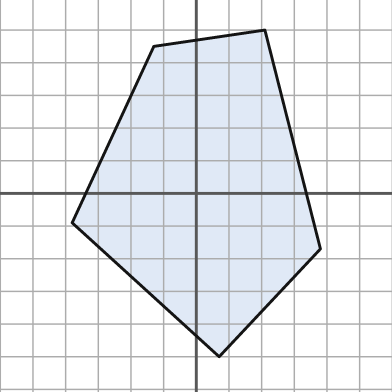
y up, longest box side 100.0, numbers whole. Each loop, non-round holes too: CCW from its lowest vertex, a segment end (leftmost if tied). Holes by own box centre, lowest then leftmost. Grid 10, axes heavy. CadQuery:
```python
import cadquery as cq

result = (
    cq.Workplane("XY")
    .moveTo(7.0, -50.0)
    .lineTo(38.0, -17.0)
    .lineTo(21.0, 50.0)
    .lineTo(-13.0, 45.0)
    .lineTo(-38.0, -9.0)
    .close()
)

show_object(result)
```